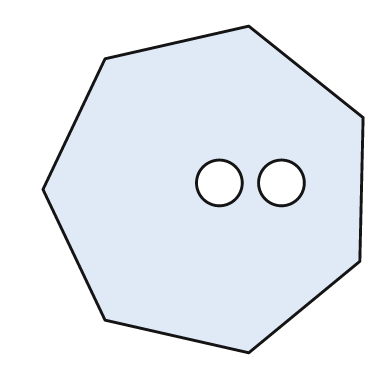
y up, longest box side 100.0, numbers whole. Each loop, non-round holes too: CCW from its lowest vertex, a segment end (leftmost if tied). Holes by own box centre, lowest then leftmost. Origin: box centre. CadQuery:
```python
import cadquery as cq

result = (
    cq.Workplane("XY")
    .moveTo(14.0, -50.0)
    .lineTo(48.0, -22.0)
    .lineTo(49.0, 22.0)
    .lineTo(14.0, 50.0)
    .lineTo(-30.0, 40.0)
    .lineTo(-49.0, 0.0)
    .lineTo(-30.0, -40.0)
    .close()
    .moveTo(5.0, 2.0)
    .circle(7.0)
    .moveTo(24.0, 2.0)
    .circle(7.0)
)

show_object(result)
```